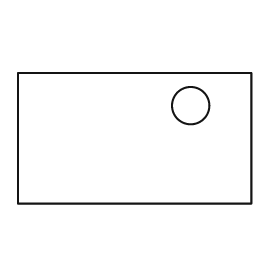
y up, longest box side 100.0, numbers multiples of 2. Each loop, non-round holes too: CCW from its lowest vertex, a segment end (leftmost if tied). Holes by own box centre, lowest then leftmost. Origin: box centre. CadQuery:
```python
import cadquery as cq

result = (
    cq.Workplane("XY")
    .moveTo(-50.0, -28.0)
    .lineTo(50.0, -28.0)
    .lineTo(50.0, 28.0)
    .lineTo(-50.0, 28.0)
    .close()
    .moveTo(24.0, 14.0)
    .circle(8.0)
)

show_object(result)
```